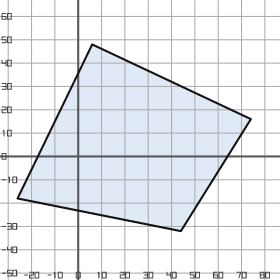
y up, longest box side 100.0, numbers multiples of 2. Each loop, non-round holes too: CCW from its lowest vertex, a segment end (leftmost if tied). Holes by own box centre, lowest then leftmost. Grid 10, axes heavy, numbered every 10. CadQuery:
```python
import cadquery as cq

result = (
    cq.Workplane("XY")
    .moveTo(44.0, -32.0)
    .lineTo(74.0, 16.0)
    .lineTo(6.0, 48.0)
    .lineTo(-26.0, -18.0)
    .close()
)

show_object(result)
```